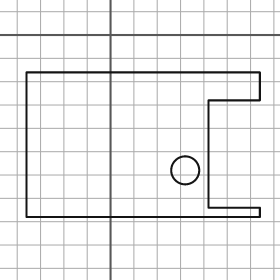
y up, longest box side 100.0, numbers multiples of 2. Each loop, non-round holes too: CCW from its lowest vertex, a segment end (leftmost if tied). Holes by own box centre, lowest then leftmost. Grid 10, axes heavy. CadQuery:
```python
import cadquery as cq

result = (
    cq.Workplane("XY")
    .moveTo(-36.0, -78.0)
    .lineTo(64.0, -78.0)
    .lineTo(64.0, -74.0)
    .lineTo(42.0, -74.0)
    .lineTo(42.0, -28.0)
    .lineTo(64.0, -28.0)
    .lineTo(64.0, -16.0)
    .lineTo(-36.0, -16.0)
    .close()
    .moveTo(32.0, -58.0)
    .circle(6.0)
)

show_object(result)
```